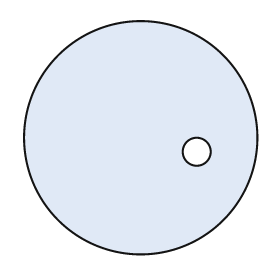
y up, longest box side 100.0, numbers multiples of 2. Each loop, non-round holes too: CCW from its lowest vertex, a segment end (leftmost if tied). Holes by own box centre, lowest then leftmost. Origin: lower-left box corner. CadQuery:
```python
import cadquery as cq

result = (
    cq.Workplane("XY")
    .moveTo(50.0, 50.0)
    .circle(50.0)
    .moveTo(74.0, 44.0)
    .circle(6.0)
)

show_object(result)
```